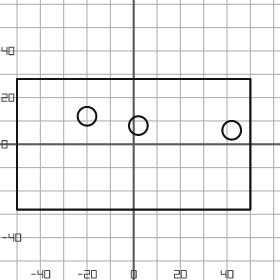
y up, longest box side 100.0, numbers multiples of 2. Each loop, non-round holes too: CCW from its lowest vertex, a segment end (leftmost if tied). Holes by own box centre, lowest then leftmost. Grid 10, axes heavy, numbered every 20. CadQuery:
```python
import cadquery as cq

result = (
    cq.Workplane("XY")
    .moveTo(-50.0, -28.0)
    .lineTo(50.0, -28.0)
    .lineTo(50.0, 28.0)
    .lineTo(-50.0, 28.0)
    .close()
    .moveTo(42.0, 6.0)
    .circle(4.0)
    .moveTo(2.0, 8.0)
    .circle(4.0)
    .moveTo(-20.0, 12.0)
    .circle(4.0)
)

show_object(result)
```